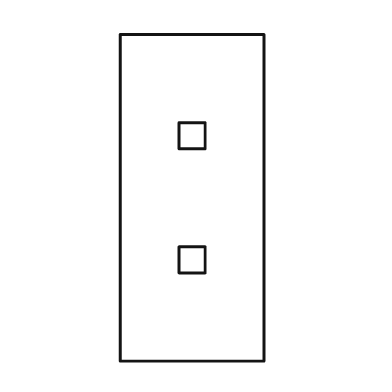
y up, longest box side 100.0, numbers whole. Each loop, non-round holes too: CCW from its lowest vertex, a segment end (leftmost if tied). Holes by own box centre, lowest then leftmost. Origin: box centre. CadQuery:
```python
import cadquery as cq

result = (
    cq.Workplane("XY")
    .moveTo(-22.0, -50.0)
    .lineTo(22.0, -50.0)
    .lineTo(22.0, 50.0)
    .lineTo(-22.0, 50.0)
    .close()
    .moveTo(-4.0, -23.0)
    .lineTo(4.0, -23.0)
    .lineTo(4.0, -15.0)
    .lineTo(-4.0, -15.0)
    .close()
    .moveTo(-4.0, 15.0)
    .lineTo(4.0, 15.0)
    .lineTo(4.0, 23.0)
    .lineTo(-4.0, 23.0)
    .close()
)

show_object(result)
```